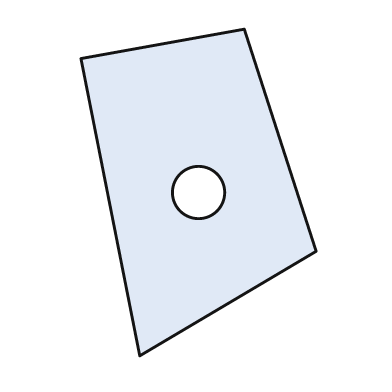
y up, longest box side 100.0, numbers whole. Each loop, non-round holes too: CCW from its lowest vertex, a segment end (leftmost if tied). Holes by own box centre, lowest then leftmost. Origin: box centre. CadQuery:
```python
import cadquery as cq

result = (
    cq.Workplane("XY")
    .moveTo(-18.0, -50.0)
    .lineTo(36.0, -18.0)
    .lineTo(14.0, 50.0)
    .lineTo(-36.0, 41.0)
    .close()
    .moveTo(0.0, 0.0)
    .circle(8.0)
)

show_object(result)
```